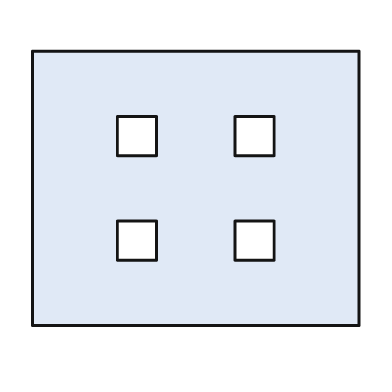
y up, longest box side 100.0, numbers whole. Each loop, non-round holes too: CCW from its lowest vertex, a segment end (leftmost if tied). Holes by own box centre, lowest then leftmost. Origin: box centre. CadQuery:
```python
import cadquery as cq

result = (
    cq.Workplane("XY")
    .moveTo(-50.0, -42.0)
    .lineTo(50.0, -42.0)
    .lineTo(50.0, 42.0)
    .lineTo(-50.0, 42.0)
    .close()
    .moveTo(-24.0, -22.0)
    .lineTo(-12.0, -22.0)
    .lineTo(-12.0, -10.0)
    .lineTo(-24.0, -10.0)
    .close()
    .moveTo(12.0, -22.0)
    .lineTo(24.0, -22.0)
    .lineTo(24.0, -10.0)
    .lineTo(12.0, -10.0)
    .close()
    .moveTo(-24.0, 10.0)
    .lineTo(-12.0, 10.0)
    .lineTo(-12.0, 22.0)
    .lineTo(-24.0, 22.0)
    .close()
    .moveTo(12.0, 10.0)
    .lineTo(24.0, 10.0)
    .lineTo(24.0, 22.0)
    .lineTo(12.0, 22.0)
    .close()
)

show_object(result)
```